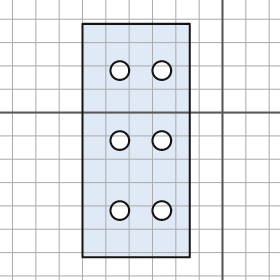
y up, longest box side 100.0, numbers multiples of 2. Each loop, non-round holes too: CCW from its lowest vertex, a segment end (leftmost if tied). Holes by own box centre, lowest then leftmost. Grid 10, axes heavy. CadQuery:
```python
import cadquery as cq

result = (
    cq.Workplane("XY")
    .moveTo(-60.0, -62.0)
    .lineTo(-14.0, -62.0)
    .lineTo(-14.0, 38.0)
    .lineTo(-60.0, 38.0)
    .close()
    .moveTo(-44.0, -42.0)
    .circle(4.0)
    .moveTo(-26.0, -42.0)
    .circle(4.0)
    .moveTo(-44.0, -12.0)
    .circle(4.0)
    .moveTo(-26.0, -12.0)
    .circle(4.0)
    .moveTo(-44.0, 18.0)
    .circle(4.0)
    .moveTo(-26.0, 18.0)
    .circle(4.0)
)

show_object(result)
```